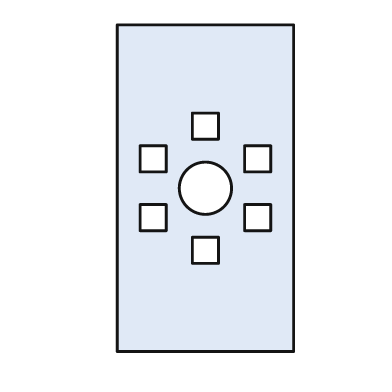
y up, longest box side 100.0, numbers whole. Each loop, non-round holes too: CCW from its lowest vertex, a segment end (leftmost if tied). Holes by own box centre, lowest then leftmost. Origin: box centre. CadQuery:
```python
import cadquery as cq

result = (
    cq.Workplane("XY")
    .moveTo(-27.0, -50.0)
    .lineTo(27.0, -50.0)
    .lineTo(27.0, 50.0)
    .lineTo(-27.0, 50.0)
    .close()
    .moveTo(-4.0, -23.0)
    .lineTo(4.0, -23.0)
    .lineTo(4.0, -15.0)
    .lineTo(-4.0, -15.0)
    .close()
    .moveTo(-20.0, -13.0)
    .lineTo(-12.0, -13.0)
    .lineTo(-12.0, -5.0)
    .lineTo(-20.0, -5.0)
    .close()
    .moveTo(12.0, -13.0)
    .lineTo(20.0, -13.0)
    .lineTo(20.0, -5.0)
    .lineTo(12.0, -5.0)
    .close()
    .moveTo(0.0, 0.0)
    .circle(8.0)
    .moveTo(-20.0, 5.0)
    .lineTo(-12.0, 5.0)
    .lineTo(-12.0, 13.0)
    .lineTo(-20.0, 13.0)
    .close()
    .moveTo(12.0, 5.0)
    .lineTo(20.0, 5.0)
    .lineTo(20.0, 13.0)
    .lineTo(12.0, 13.0)
    .close()
    .moveTo(-4.0, 15.0)
    .lineTo(4.0, 15.0)
    .lineTo(4.0, 23.0)
    .lineTo(-4.0, 23.0)
    .close()
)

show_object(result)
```